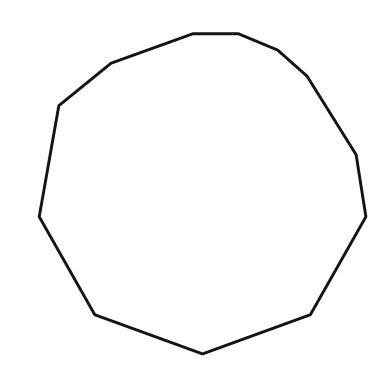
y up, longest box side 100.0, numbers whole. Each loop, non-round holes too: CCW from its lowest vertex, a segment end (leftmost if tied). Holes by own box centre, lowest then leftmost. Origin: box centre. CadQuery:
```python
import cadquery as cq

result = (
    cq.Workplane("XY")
    .moveTo(0.0, -49.0)
    .lineTo(33.0, -37.0)
    .lineTo(50.0, -7.0)
    .lineTo(47.0, 12.0)
    .lineTo(32.0, 36.0)
    .lineTo(23.0, 44.0)
    .lineTo(11.0, 49.0)
    .lineTo(-3.0, 49.0)
    .lineTo(-28.0, 40.0)
    .lineTo(-44.0, 27.0)
    .lineTo(-50.0, -7.0)
    .lineTo(-33.0, -37.0)
    .close()
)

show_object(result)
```